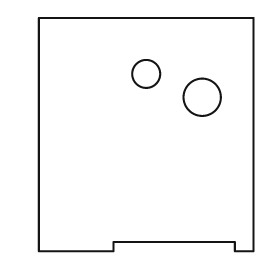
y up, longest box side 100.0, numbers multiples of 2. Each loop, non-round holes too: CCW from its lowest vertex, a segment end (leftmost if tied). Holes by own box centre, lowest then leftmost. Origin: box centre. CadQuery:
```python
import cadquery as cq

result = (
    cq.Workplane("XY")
    .moveTo(-46.0, -50.0)
    .lineTo(-14.0, -50.0)
    .lineTo(-14.0, -46.0)
    .lineTo(38.0, -46.0)
    .lineTo(38.0, -50.0)
    .lineTo(46.0, -50.0)
    .lineTo(46.0, 50.0)
    .lineTo(-46.0, 50.0)
    .close()
    .moveTo(24.0, 16.0)
    .circle(8.0)
    .moveTo(0.0, 26.0)
    .circle(6.0)
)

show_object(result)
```